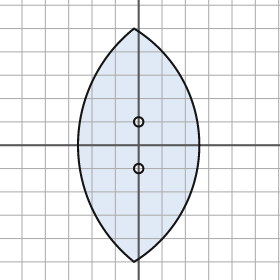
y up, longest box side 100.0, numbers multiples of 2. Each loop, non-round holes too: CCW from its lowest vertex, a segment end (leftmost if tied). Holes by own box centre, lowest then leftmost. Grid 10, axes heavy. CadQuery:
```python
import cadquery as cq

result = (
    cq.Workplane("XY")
    .moveTo(-2.0, -50.0)
    .threePointArc((26.0, 0.0), (-2.0, 50.0))
    .threePointArc((-26.0, 0.0), (-2.0, -50.0))
    .close()
    .moveTo(0.0, -10.0)
    .circle(2.0)
    .moveTo(0.0, 10.0)
    .circle(2.0)
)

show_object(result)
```